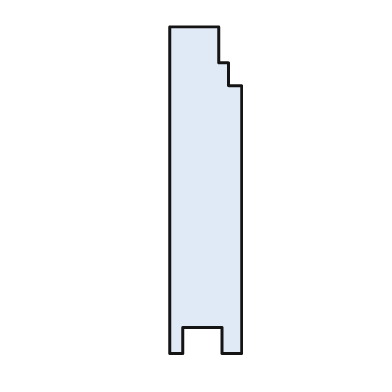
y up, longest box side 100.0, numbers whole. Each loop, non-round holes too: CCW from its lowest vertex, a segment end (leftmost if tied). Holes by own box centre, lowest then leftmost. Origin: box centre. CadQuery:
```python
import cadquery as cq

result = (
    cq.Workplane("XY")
    .moveTo(-11.0, -50.0)
    .lineTo(-7.0, -50.0)
    .lineTo(-7.0, -42.0)
    .lineTo(5.0, -42.0)
    .lineTo(5.0, -50.0)
    .lineTo(11.0, -50.0)
    .lineTo(11.0, 32.0)
    .lineTo(7.0, 32.0)
    .lineTo(7.0, 39.0)
    .lineTo(4.0, 39.0)
    .lineTo(4.0, 50.0)
    .lineTo(-11.0, 50.0)
    .close()
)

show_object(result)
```